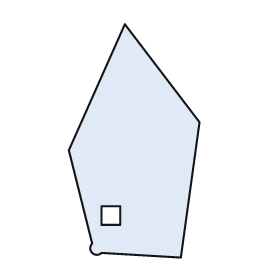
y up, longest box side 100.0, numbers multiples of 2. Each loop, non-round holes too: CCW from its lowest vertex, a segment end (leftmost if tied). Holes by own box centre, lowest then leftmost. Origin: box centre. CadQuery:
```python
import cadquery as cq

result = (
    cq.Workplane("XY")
    .moveTo(20.0, -50.0)
    .lineTo(28.0, 8.0)
    .lineTo(-4.0, 50.0)
    .lineTo(-28.0, -4.0)
    .lineTo(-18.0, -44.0)
    .threePointArc((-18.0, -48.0), (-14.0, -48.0))
    .close()
    .moveTo(-14.0, -36.0)
    .lineTo(-6.0, -36.0)
    .lineTo(-6.0, -28.0)
    .lineTo(-14.0, -28.0)
    .close()
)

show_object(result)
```